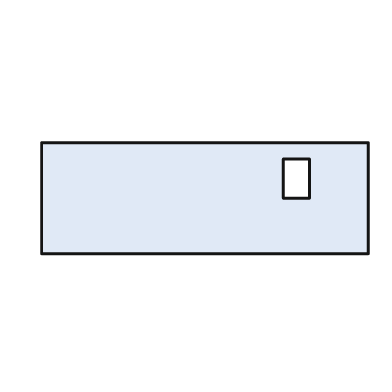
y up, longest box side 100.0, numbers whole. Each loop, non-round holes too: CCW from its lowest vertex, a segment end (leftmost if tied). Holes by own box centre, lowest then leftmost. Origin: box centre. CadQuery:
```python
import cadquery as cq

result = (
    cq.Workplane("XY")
    .moveTo(-50.0, -17.0)
    .lineTo(50.0, -17.0)
    .lineTo(50.0, 17.0)
    .lineTo(-50.0, 17.0)
    .close()
    .moveTo(24.0, 0.0)
    .lineTo(32.0, 0.0)
    .lineTo(32.0, 12.0)
    .lineTo(24.0, 12.0)
    .close()
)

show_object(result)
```